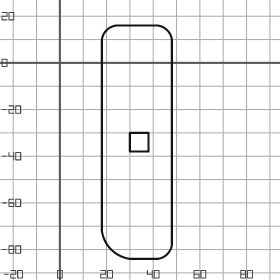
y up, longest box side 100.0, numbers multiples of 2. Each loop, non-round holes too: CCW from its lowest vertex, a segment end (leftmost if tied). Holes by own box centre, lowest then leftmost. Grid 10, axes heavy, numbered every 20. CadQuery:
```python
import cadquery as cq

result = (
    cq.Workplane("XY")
    .moveTo(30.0, -84.0)
    .lineTo(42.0, -84.0)
    .threePointArc((46.0, -82.0), (48.0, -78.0))
    .lineTo(48.0, 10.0)
    .threePointArc((46.0, 14.0), (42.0, 16.0))
    .lineTo(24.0, 16.0)
    .threePointArc((20.0, 14.0), (18.0, 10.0))
    .lineTo(18.0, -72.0)
    .threePointArc((22.0, -80.0), (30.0, -84.0))
    .close()
    .moveTo(30.0, -38.0)
    .lineTo(38.0, -38.0)
    .lineTo(38.0, -30.0)
    .lineTo(30.0, -30.0)
    .close()
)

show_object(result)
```